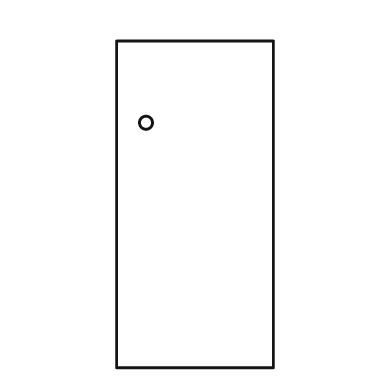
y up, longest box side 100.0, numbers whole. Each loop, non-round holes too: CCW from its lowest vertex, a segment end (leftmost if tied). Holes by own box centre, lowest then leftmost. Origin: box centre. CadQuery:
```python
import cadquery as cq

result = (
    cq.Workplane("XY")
    .moveTo(-24.0, -50.0)
    .lineTo(24.0, -50.0)
    .lineTo(24.0, 50.0)
    .lineTo(-24.0, 50.0)
    .close()
    .moveTo(-15.0, 25.0)
    .circle(2.0)
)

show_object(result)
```